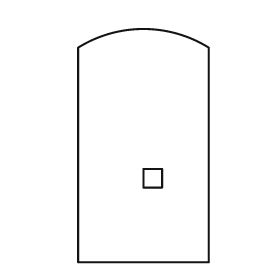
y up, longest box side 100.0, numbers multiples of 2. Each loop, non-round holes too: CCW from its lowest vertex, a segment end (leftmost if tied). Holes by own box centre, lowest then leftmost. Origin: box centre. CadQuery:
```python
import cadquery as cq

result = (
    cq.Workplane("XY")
    .moveTo(-28.0, -50.0)
    .lineTo(28.0, -50.0)
    .lineTo(28.0, 42.0)
    .threePointArc((0.0, 50.0), (-28.0, 42.0))
    .close()
    .moveTo(0.0, -18.0)
    .lineTo(8.0, -18.0)
    .lineTo(8.0, -10.0)
    .lineTo(0.0, -10.0)
    .close()
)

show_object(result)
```